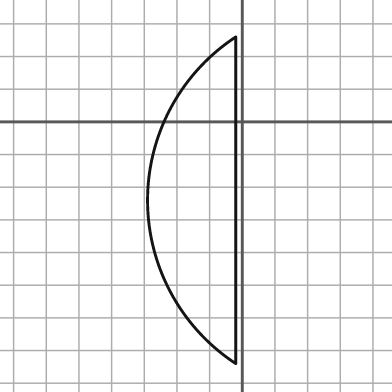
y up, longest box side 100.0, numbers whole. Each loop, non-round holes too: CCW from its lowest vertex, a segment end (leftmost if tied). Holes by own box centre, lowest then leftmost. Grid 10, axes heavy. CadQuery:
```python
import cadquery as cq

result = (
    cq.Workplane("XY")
    .moveTo(-2.0, -74.0)
    .lineTo(-2.0, 26.0)
    .threePointArc((-29.0, -24.0), (-2.0, -74.0))
    .close()
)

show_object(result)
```